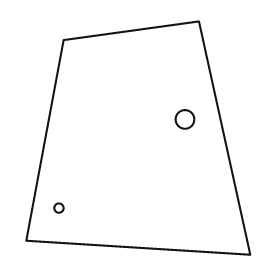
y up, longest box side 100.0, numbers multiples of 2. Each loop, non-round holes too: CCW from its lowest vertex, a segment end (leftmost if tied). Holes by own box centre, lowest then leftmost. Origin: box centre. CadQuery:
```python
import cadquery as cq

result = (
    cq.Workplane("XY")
    .moveTo(48.0, -50.0)
    .lineTo(26.0, 50.0)
    .lineTo(-32.0, 42.0)
    .lineTo(-48.0, -44.0)
    .close()
    .moveTo(-34.0, -30.0)
    .circle(2.0)
    .moveTo(20.0, 8.0)
    .circle(4.0)
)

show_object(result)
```